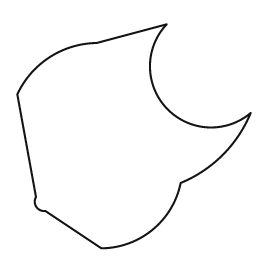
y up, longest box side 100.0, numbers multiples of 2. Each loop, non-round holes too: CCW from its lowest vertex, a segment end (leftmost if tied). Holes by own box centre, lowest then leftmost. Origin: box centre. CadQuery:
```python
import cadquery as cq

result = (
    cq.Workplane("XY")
    .moveTo(-14.0, -48.0)
    .threePointArc((8.0, -40.0), (20.0, -20.0))
    .threePointArc((38.0, -8.0), (50.0, 10.0))
    .threePointArc((14.0, 12.0), (14.0, 48.0))
    .lineTo(-16.0, 40.0)
    .threePointArc((-36.0, 34.0), (-50.0, 18.0))
    .lineTo(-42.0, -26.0)
    .threePointArc((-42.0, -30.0), (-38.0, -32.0))
    .close()
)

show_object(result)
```